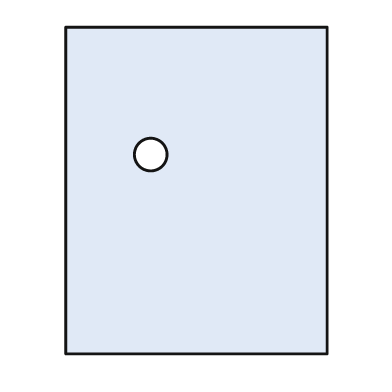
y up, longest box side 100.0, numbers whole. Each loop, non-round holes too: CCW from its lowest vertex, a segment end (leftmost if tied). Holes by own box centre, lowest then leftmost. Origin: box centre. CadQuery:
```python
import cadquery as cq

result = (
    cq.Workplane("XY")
    .moveTo(-40.0, -50.0)
    .lineTo(40.0, -50.0)
    .lineTo(40.0, 50.0)
    .lineTo(-40.0, 50.0)
    .close()
    .moveTo(-14.0, 11.0)
    .circle(5.0)
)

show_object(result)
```